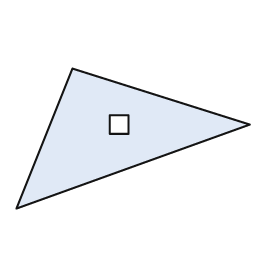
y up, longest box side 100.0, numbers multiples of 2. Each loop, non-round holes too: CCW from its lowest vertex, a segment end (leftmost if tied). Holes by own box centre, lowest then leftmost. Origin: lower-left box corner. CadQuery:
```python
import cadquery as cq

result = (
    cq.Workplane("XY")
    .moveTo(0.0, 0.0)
    .lineTo(100.0, 36.0)
    .lineTo(24.0, 60.0)
    .close()
    .moveTo(40.0, 32.0)
    .lineTo(48.0, 32.0)
    .lineTo(48.0, 40.0)
    .lineTo(40.0, 40.0)
    .close()
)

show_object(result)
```